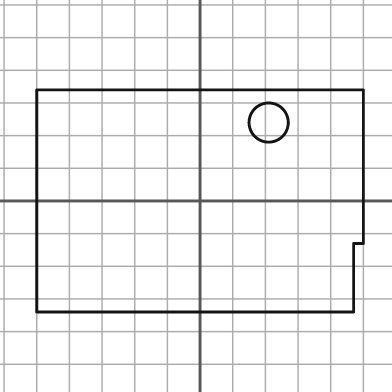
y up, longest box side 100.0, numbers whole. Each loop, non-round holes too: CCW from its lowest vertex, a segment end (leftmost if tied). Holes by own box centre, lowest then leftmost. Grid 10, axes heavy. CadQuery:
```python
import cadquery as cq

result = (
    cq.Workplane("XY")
    .moveTo(-50.0, -34.0)
    .lineTo(47.0, -34.0)
    .lineTo(47.0, -13.0)
    .lineTo(50.0, -13.0)
    .lineTo(50.0, 34.0)
    .lineTo(-50.0, 34.0)
    .close()
    .moveTo(21.0, 24.0)
    .circle(6.0)
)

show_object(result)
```